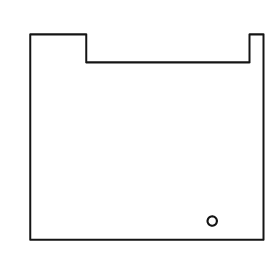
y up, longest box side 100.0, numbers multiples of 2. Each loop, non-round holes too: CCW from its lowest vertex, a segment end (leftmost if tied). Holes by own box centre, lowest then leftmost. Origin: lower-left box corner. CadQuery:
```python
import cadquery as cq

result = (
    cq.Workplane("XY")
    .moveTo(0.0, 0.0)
    .lineTo(100.0, 0.0)
    .lineTo(100.0, 88.0)
    .lineTo(94.0, 88.0)
    .lineTo(94.0, 76.0)
    .lineTo(24.0, 76.0)
    .lineTo(24.0, 88.0)
    .lineTo(0.0, 88.0)
    .close()
    .moveTo(78.0, 8.0)
    .circle(2.0)
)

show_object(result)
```